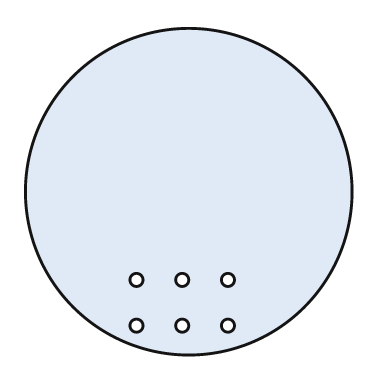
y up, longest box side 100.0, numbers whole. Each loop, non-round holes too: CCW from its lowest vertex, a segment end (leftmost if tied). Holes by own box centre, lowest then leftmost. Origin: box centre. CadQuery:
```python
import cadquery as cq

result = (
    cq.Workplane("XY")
    .moveTo(0.0, 0.0)
    .circle(50.0)
    .moveTo(-16.0, -41.0)
    .circle(2.0)
    .moveTo(-2.0, -41.0)
    .circle(2.0)
    .moveTo(12.0, -41.0)
    .circle(2.0)
    .moveTo(-16.0, -27.0)
    .circle(2.0)
    .moveTo(-2.0, -27.0)
    .circle(2.0)
    .moveTo(12.0, -27.0)
    .circle(2.0)
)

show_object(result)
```